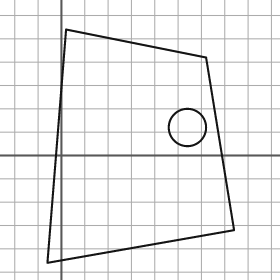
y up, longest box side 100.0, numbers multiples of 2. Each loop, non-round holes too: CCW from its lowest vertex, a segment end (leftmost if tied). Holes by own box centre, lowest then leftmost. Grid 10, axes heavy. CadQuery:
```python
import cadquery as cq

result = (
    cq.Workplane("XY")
    .moveTo(-6.0, -46.0)
    .lineTo(74.0, -32.0)
    .lineTo(62.0, 42.0)
    .lineTo(2.0, 54.0)
    .close()
    .moveTo(54.0, 12.0)
    .circle(8.0)
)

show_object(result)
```